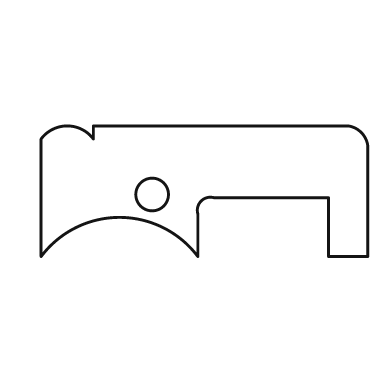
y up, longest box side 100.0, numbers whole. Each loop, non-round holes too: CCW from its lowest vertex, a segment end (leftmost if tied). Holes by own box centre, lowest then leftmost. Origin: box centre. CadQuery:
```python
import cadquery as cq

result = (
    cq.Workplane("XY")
    .moveTo(-50.0, -20.0)
    .threePointArc((-26.0, -8.0), (-2.0, -20.0))
    .lineTo(-2.0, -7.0)
    .threePointArc((-1.0, -3.0), (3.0, -2.0))
    .lineTo(38.0, -2.0)
    .lineTo(38.0, -20.0)
    .lineTo(50.0, -20.0)
    .lineTo(50.0, 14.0)
    .threePointArc((48.0, 18.0), (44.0, 20.0))
    .lineTo(-34.0, 20.0)
    .lineTo(-34.0, 16.0)
    .threePointArc((-42.0, 20.0), (-50.0, 16.0))
    .close()
    .moveTo(-16.0, -1.0)
    .circle(5.0)
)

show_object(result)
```